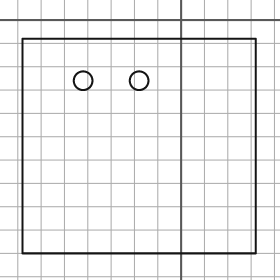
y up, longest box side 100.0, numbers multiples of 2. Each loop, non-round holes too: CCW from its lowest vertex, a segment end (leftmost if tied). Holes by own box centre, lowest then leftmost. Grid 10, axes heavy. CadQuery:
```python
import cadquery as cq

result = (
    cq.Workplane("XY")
    .moveTo(-68.0, -100.0)
    .lineTo(32.0, -100.0)
    .lineTo(32.0, -8.0)
    .lineTo(-68.0, -8.0)
    .close()
    .moveTo(-42.0, -26.0)
    .circle(4.0)
    .moveTo(-18.0, -26.0)
    .circle(4.0)
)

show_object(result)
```